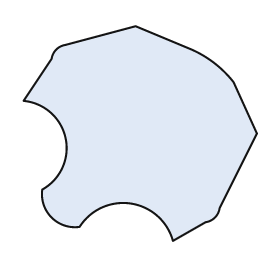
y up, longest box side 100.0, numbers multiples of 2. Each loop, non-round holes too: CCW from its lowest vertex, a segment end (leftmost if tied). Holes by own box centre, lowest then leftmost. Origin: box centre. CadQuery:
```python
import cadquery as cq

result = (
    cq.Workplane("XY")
    .moveTo(14.0, -46.0)
    .lineTo(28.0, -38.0)
    .threePointArc((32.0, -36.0), (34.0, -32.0))
    .lineTo(50.0, 0.0)
    .lineTo(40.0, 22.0)
    .threePointArc((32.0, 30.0), (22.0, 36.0))
    .lineTo(-2.0, 46.0)
    .lineTo(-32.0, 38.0)
    .threePointArc((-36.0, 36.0), (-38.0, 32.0))
    .lineTo(-50.0, 14.0)
    .threePointArc((-32.0, -2.0), (-42.0, -24.0))
    .threePointArc((-38.0, -36.0), (-26.0, -40.0))
    .threePointArc((-4.0, -30.0), (14.0, -46.0))
    .close()
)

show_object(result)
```